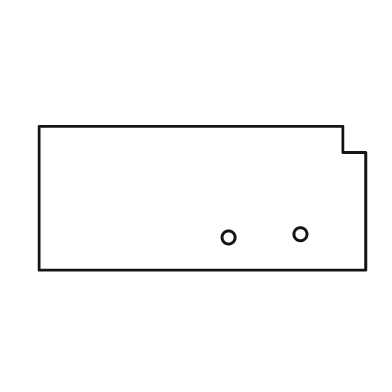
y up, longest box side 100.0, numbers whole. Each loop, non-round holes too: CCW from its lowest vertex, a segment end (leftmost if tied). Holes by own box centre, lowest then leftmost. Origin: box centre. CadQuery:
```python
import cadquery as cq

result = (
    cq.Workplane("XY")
    .moveTo(-50.0, -22.0)
    .lineTo(50.0, -22.0)
    .lineTo(50.0, 14.0)
    .lineTo(43.0, 14.0)
    .lineTo(43.0, 22.0)
    .lineTo(-50.0, 22.0)
    .close()
    .moveTo(8.0, -12.0)
    .circle(2.0)
    .moveTo(30.0, -11.0)
    .circle(2.0)
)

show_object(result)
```